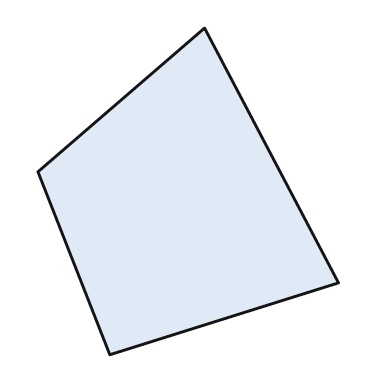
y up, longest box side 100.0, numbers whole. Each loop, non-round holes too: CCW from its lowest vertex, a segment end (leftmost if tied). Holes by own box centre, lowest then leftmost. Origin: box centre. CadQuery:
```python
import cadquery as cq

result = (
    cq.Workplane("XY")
    .moveTo(-24.0, -50.0)
    .lineTo(46.0, -28.0)
    .lineTo(5.0, 50.0)
    .lineTo(-46.0, 6.0)
    .close()
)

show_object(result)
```